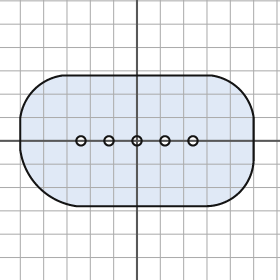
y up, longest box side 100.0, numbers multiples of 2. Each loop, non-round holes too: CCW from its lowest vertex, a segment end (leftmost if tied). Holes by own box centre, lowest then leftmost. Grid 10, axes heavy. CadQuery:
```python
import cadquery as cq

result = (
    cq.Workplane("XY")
    .moveTo(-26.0, -28.0)
    .lineTo(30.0, -28.0)
    .threePointArc((44.0, -22.0), (50.0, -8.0))
    .lineTo(50.0, 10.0)
    .threePointArc((44.0, 22.0), (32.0, 28.0))
    .lineTo(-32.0, 28.0)
    .threePointArc((-44.0, 22.0), (-50.0, 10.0))
    .lineTo(-50.0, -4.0)
    .threePointArc((-42.0, -20.0), (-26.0, -28.0))
    .close()
    .moveTo(-24.0, 0.0)
    .circle(2.0)
    .moveTo(-12.0, 0.0)
    .circle(2.0)
    .moveTo(0.0, 0.0)
    .circle(2.0)
    .moveTo(12.0, 0.0)
    .circle(2.0)
    .moveTo(24.0, 0.0)
    .circle(2.0)
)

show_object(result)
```